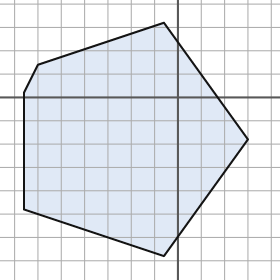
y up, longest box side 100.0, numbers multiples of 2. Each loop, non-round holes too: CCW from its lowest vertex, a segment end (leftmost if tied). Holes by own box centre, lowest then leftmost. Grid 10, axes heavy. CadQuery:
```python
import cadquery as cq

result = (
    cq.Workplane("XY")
    .moveTo(-6.0, -68.0)
    .lineTo(30.0, -18.0)
    .lineTo(-6.0, 32.0)
    .lineTo(-60.0, 14.0)
    .lineTo(-66.0, 2.0)
    .lineTo(-66.0, -48.0)
    .close()
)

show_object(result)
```